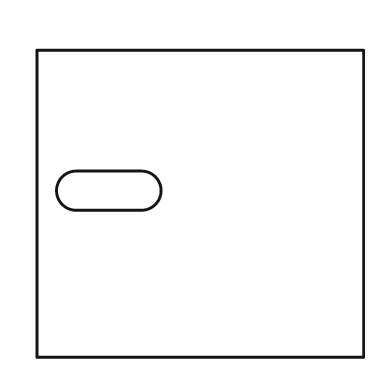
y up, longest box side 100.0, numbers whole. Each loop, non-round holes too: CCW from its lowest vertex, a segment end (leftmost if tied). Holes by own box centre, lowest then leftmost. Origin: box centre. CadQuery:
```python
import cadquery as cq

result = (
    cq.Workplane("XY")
    .moveTo(-50.0, -47.0)
    .lineTo(50.0, -47.0)
    .lineTo(50.0, 47.0)
    .lineTo(-50.0, 47.0)
    .close()
    .moveTo(-38.0, -2.0)
    .lineTo(-18.0, -2.0)
    .threePointArc((-12.0, 4.0), (-18.0, 10.0))
    .lineTo(-38.0, 10.0)
    .threePointArc((-44.0, 4.0), (-38.0, -2.0))
    .close()
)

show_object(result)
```